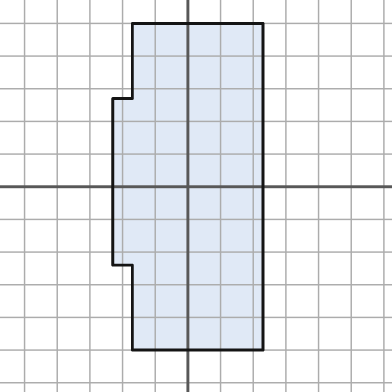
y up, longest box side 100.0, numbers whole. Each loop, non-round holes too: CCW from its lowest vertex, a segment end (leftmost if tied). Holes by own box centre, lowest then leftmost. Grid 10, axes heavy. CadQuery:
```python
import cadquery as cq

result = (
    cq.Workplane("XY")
    .moveTo(-17.0, -50.0)
    .lineTo(23.0, -50.0)
    .lineTo(23.0, 50.0)
    .lineTo(-17.0, 50.0)
    .lineTo(-17.0, 27.0)
    .lineTo(-23.0, 27.0)
    .lineTo(-23.0, -24.0)
    .lineTo(-17.0, -24.0)
    .close()
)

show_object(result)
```